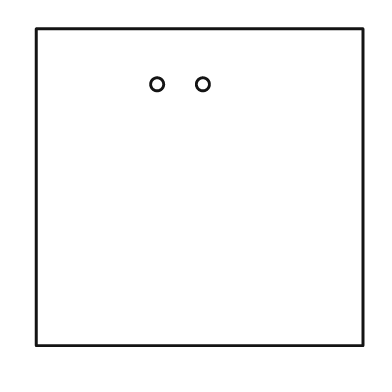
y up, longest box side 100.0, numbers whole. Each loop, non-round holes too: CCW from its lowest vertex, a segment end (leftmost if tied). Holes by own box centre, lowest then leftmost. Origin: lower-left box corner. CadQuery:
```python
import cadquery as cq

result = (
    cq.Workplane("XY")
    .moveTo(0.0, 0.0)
    .lineTo(100.0, 0.0)
    .lineTo(100.0, 97.0)
    .lineTo(0.0, 97.0)
    .close()
    .moveTo(37.0, 80.0)
    .circle(2.0)
    .moveTo(51.0, 80.0)
    .circle(2.0)
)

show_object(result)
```